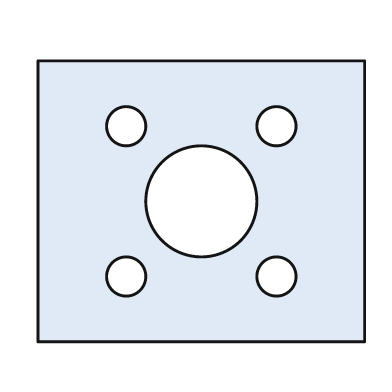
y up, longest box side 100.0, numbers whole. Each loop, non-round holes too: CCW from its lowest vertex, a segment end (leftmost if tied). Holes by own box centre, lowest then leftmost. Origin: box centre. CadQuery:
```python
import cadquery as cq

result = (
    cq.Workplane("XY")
    .moveTo(-50.0, -43.0)
    .lineTo(50.0, -43.0)
    .lineTo(50.0, 43.0)
    .lineTo(-50.0, 43.0)
    .close()
    .moveTo(-23.0, -23.0)
    .circle(6.0)
    .moveTo(23.0, -23.0)
    .circle(6.0)
    .moveTo(0.0, 0.0)
    .circle(17.0)
    .moveTo(-23.0, 23.0)
    .circle(6.0)
    .moveTo(23.0, 23.0)
    .circle(6.0)
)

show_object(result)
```